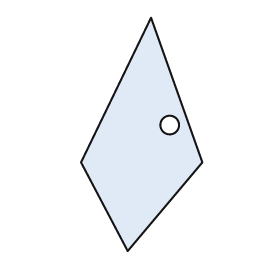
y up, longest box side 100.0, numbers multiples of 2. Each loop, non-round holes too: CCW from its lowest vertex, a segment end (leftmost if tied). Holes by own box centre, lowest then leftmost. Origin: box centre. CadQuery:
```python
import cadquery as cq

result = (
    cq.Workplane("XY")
    .moveTo(-6.0, -50.0)
    .lineTo(26.0, -12.0)
    .lineTo(4.0, 50.0)
    .lineTo(-26.0, -12.0)
    .close()
    .moveTo(12.0, 4.0)
    .circle(4.0)
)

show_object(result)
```